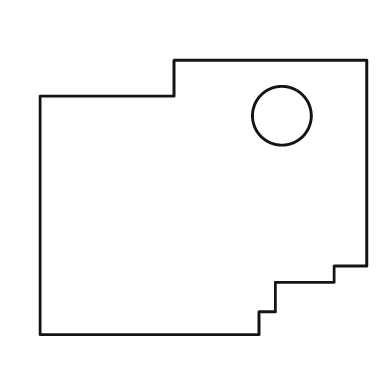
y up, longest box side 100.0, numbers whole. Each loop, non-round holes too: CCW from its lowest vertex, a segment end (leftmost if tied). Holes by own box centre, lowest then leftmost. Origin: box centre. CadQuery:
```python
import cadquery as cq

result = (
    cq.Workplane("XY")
    .moveTo(-50.0, -42.0)
    .lineTo(17.0, -42.0)
    .lineTo(17.0, -35.0)
    .lineTo(22.0, -35.0)
    .lineTo(22.0, -26.0)
    .lineTo(40.0, -26.0)
    .lineTo(40.0, -21.0)
    .lineTo(50.0, -21.0)
    .lineTo(50.0, 42.0)
    .lineTo(-9.0, 42.0)
    .lineTo(-9.0, 31.0)
    .lineTo(-50.0, 31.0)
    .close()
    .moveTo(24.0, 25.0)
    .circle(9.0)
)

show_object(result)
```